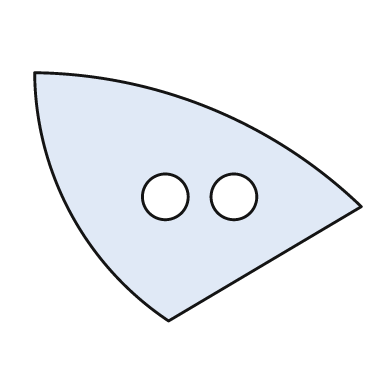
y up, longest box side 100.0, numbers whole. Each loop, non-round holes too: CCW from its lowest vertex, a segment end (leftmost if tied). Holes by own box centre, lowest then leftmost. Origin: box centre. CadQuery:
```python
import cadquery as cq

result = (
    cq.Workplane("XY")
    .moveTo(-9.0, -38.0)
    .lineTo(50.0, -3.0)
    .threePointArc((4.0, 27.0), (-50.0, 38.0))
    .threePointArc((-39.0, -5.0), (-9.0, -38.0))
    .close()
    .moveTo(-10.0, 0.0)
    .circle(7.0)
    .moveTo(11.0, 0.0)
    .circle(7.0)
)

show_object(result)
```